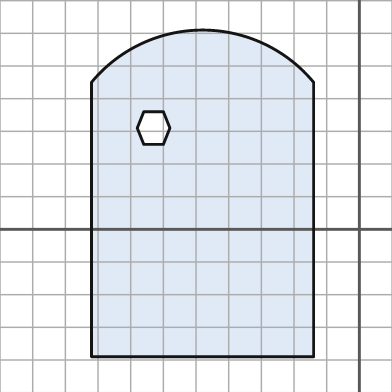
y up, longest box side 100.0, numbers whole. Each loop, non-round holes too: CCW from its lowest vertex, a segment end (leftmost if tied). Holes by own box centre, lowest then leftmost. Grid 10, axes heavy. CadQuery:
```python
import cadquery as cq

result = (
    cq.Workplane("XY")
    .moveTo(-82.0, -39.0)
    .lineTo(-14.0, -39.0)
    .lineTo(-14.0, 45.0)
    .threePointArc((-48.0, 61.0), (-82.0, 45.0))
    .close()
    .moveTo(-66.0, 26.0)
    .lineTo(-60.0, 26.0)
    .lineTo(-58.0, 31.0)
    .lineTo(-60.0, 36.0)
    .lineTo(-66.0, 36.0)
    .lineTo(-68.0, 31.0)
    .close()
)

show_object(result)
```